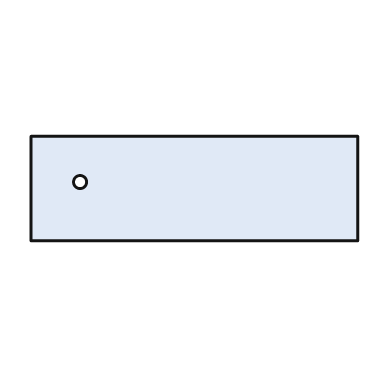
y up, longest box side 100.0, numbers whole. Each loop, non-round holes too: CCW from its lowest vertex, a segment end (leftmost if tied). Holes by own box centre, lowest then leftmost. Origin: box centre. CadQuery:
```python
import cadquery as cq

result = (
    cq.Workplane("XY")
    .moveTo(-50.0, -16.0)
    .lineTo(50.0, -16.0)
    .lineTo(50.0, 16.0)
    .lineTo(-50.0, 16.0)
    .close()
    .moveTo(-35.0, 2.0)
    .circle(2.0)
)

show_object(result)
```